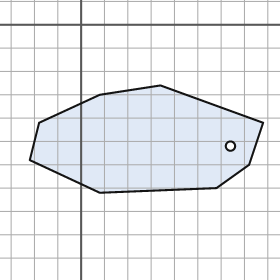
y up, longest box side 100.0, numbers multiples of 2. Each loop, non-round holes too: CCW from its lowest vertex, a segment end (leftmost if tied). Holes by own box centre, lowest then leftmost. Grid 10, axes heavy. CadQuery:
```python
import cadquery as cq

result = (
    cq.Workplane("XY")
    .moveTo(8.0, -72.0)
    .lineTo(58.0, -70.0)
    .lineTo(72.0, -60.0)
    .lineTo(78.0, -42.0)
    .lineTo(34.0, -26.0)
    .lineTo(8.0, -30.0)
    .lineTo(-18.0, -42.0)
    .lineTo(-22.0, -58.0)
    .close()
    .moveTo(64.0, -52.0)
    .circle(2.0)
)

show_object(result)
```